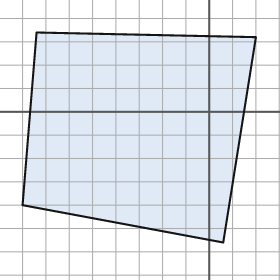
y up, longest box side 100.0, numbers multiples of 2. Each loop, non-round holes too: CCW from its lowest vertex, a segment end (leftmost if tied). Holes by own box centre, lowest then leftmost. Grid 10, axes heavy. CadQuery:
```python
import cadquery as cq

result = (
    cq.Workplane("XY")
    .moveTo(6.0, -56.0)
    .lineTo(20.0, 32.0)
    .lineTo(-74.0, 34.0)
    .lineTo(-80.0, -40.0)
    .close()
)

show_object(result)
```